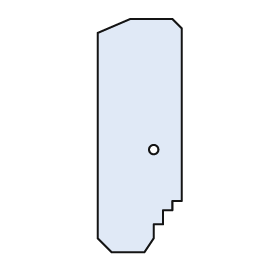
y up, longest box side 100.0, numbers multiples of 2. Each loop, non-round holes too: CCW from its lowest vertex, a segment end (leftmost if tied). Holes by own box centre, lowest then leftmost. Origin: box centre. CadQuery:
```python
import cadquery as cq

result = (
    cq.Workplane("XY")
    .moveTo(-12.0, -50.0)
    .lineTo(2.0, -50.0)
    .lineTo(6.0, -44.0)
    .lineTo(6.0, -38.0)
    .lineTo(10.0, -38.0)
    .lineTo(10.0, -32.0)
    .lineTo(14.0, -32.0)
    .lineTo(14.0, -28.0)
    .lineTo(18.0, -28.0)
    .lineTo(18.0, 46.0)
    .lineTo(14.0, 50.0)
    .lineTo(-4.0, 50.0)
    .lineTo(-18.0, 44.0)
    .lineTo(-18.0, -44.0)
    .close()
    .moveTo(6.0, -6.0)
    .circle(2.0)
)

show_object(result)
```